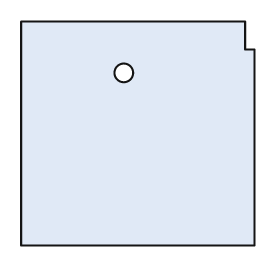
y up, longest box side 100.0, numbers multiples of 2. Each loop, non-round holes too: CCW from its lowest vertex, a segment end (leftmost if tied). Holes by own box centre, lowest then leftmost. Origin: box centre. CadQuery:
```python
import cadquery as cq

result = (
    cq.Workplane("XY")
    .moveTo(-50.0, -48.0)
    .lineTo(50.0, -48.0)
    .lineTo(50.0, 36.0)
    .lineTo(46.0, 36.0)
    .lineTo(46.0, 48.0)
    .lineTo(-50.0, 48.0)
    .close()
    .moveTo(-6.0, 26.0)
    .circle(4.0)
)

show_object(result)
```